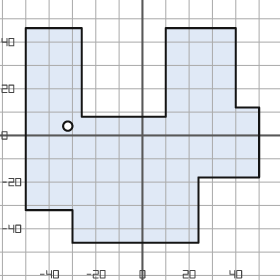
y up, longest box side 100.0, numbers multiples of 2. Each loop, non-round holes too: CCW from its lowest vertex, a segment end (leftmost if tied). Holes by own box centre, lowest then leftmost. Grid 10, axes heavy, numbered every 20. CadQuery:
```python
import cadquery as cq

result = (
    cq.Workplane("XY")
    .moveTo(-30.0, -46.0)
    .lineTo(24.0, -46.0)
    .lineTo(24.0, -18.0)
    .lineTo(50.0, -18.0)
    .lineTo(50.0, 12.0)
    .lineTo(40.0, 12.0)
    .lineTo(40.0, 46.0)
    .lineTo(10.0, 46.0)
    .lineTo(10.0, 8.0)
    .lineTo(-26.0, 8.0)
    .lineTo(-26.0, 46.0)
    .lineTo(-50.0, 46.0)
    .lineTo(-50.0, -32.0)
    .lineTo(-30.0, -32.0)
    .close()
    .moveTo(-32.0, 4.0)
    .circle(2.0)
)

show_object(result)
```